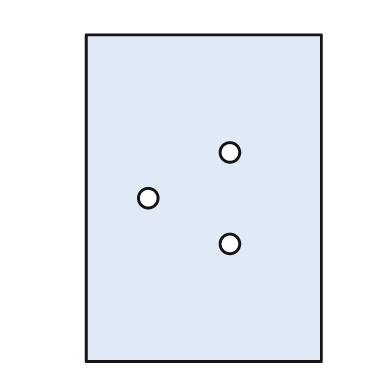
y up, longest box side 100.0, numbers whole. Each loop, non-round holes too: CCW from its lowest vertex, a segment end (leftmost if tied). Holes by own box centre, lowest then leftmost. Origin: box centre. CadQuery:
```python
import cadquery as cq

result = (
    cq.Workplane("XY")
    .moveTo(-36.0, -50.0)
    .lineTo(36.0, -50.0)
    .lineTo(36.0, 50.0)
    .lineTo(-36.0, 50.0)
    .close()
    .moveTo(8.0, -14.0)
    .circle(3.0)
    .moveTo(-17.0, 0.0)
    .circle(3.0)
    .moveTo(8.0, 14.0)
    .circle(3.0)
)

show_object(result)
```